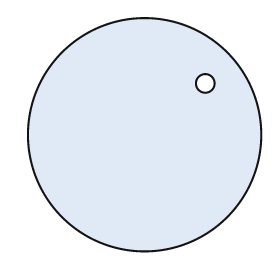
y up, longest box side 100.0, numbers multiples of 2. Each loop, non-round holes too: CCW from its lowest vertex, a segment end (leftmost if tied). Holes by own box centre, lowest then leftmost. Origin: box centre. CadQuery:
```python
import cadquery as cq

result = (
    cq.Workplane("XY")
    .moveTo(0.0, 0.0)
    .circle(50.0)
    .moveTo(26.0, 22.0)
    .circle(4.0)
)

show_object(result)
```